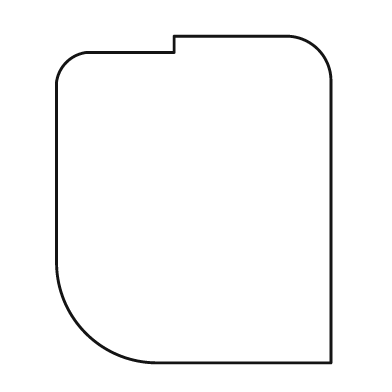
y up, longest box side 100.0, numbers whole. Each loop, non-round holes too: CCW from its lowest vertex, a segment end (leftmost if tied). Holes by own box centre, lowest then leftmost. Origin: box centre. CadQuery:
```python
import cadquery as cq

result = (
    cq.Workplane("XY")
    .moveTo(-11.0, -50.0)
    .lineTo(42.0, -50.0)
    .lineTo(42.0, 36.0)
    .threePointArc((38.0, 46.0), (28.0, 50.0))
    .lineTo(-6.0, 50.0)
    .lineTo(-6.0, 45.0)
    .lineTo(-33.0, 45.0)
    .threePointArc((-39.0, 42.0), (-42.0, 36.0))
    .lineTo(-42.0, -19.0)
    .threePointArc((-33.0, -41.0), (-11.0, -50.0))
    .close()
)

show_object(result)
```